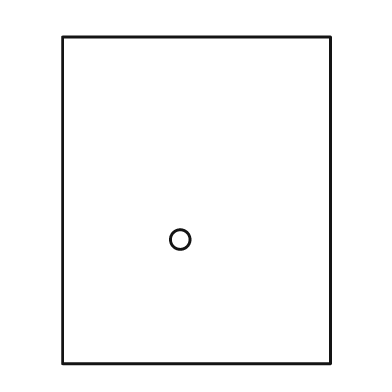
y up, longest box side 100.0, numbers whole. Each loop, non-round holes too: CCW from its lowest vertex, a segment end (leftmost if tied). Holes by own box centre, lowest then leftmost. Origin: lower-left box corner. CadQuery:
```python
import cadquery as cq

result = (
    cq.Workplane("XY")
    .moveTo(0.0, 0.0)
    .lineTo(82.0, 0.0)
    .lineTo(82.0, 100.0)
    .lineTo(0.0, 100.0)
    .close()
    .moveTo(36.0, 38.0)
    .circle(3.0)
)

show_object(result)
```